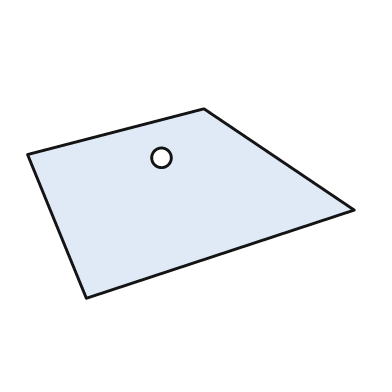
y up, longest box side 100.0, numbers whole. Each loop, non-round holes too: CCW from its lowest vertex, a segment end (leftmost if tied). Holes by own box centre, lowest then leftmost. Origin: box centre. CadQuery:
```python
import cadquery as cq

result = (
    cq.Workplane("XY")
    .moveTo(-32.0, -29.0)
    .lineTo(50.0, -2.0)
    .lineTo(4.0, 29.0)
    .lineTo(-50.0, 15.0)
    .close()
    .moveTo(-9.0, 14.0)
    .circle(3.0)
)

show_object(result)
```